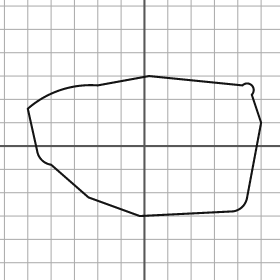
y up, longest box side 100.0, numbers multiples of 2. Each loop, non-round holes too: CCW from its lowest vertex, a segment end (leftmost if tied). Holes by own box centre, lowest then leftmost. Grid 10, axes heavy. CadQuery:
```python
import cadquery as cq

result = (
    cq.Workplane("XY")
    .moveTo(-2.0, -30.0)
    .lineTo(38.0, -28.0)
    .threePointArc((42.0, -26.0), (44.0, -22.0))
    .lineTo(50.0, 10.0)
    .lineTo(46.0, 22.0)
    .threePointArc((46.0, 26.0), (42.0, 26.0))
    .lineTo(2.0, 30.0)
    .lineTo(-20.0, 26.0)
    .threePointArc((-36.0, 24.0), (-50.0, 16.0))
    .lineTo(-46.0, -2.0)
    .threePointArc((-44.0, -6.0), (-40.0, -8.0))
    .lineTo(-24.0, -22.0)
    .close()
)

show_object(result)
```